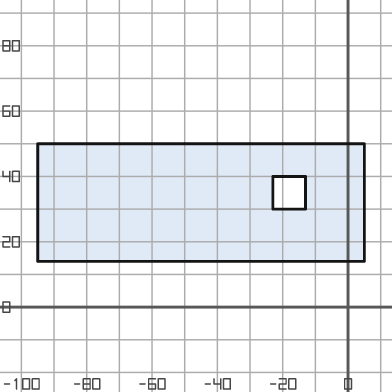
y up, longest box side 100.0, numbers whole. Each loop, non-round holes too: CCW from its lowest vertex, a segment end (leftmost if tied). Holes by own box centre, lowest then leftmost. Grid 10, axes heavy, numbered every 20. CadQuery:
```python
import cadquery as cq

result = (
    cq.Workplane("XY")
    .moveTo(-95.0, 14.0)
    .lineTo(5.0, 14.0)
    .lineTo(5.0, 50.0)
    .lineTo(-95.0, 50.0)
    .close()
    .moveTo(-23.0, 30.0)
    .lineTo(-13.0, 30.0)
    .lineTo(-13.0, 40.0)
    .lineTo(-23.0, 40.0)
    .close()
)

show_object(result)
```